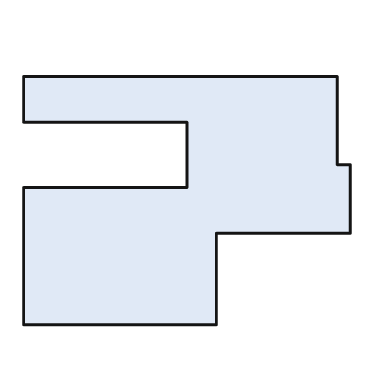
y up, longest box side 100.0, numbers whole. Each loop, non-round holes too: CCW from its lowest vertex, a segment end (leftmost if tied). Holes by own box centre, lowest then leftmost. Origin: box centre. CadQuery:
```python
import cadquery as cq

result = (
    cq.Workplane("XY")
    .moveTo(-50.0, -38.0)
    .lineTo(9.0, -38.0)
    .lineTo(9.0, -10.0)
    .lineTo(50.0, -10.0)
    .lineTo(50.0, 11.0)
    .lineTo(46.0, 11.0)
    .lineTo(46.0, 38.0)
    .lineTo(-50.0, 38.0)
    .lineTo(-50.0, 24.0)
    .lineTo(0.0, 24.0)
    .lineTo(0.0, 4.0)
    .lineTo(-50.0, 4.0)
    .close()
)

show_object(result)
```